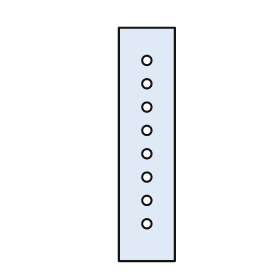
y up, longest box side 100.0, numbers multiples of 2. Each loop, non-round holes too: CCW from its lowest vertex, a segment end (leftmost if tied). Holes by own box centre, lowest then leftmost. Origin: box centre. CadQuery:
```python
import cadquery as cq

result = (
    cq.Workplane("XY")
    .moveTo(-12.0, -50.0)
    .lineTo(12.0, -50.0)
    .lineTo(12.0, 50.0)
    .lineTo(-12.0, 50.0)
    .close()
    .moveTo(0.0, -34.0)
    .circle(2.0)
    .moveTo(0.0, -24.0)
    .circle(2.0)
    .moveTo(0.0, -14.0)
    .circle(2.0)
    .moveTo(0.0, -4.0)
    .circle(2.0)
    .moveTo(0.0, 6.0)
    .circle(2.0)
    .moveTo(0.0, 16.0)
    .circle(2.0)
    .moveTo(0.0, 26.0)
    .circle(2.0)
    .moveTo(0.0, 36.0)
    .circle(2.0)
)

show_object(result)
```